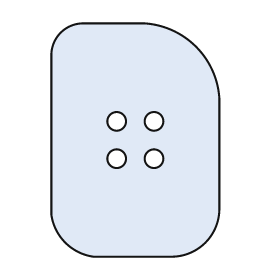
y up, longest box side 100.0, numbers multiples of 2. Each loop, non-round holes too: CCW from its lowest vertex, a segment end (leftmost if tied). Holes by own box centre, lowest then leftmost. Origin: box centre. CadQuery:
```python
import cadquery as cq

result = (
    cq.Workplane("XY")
    .moveTo(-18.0, -50.0)
    .lineTo(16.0, -50.0)
    .threePointArc((30.0, -44.0), (36.0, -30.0))
    .lineTo(36.0, 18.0)
    .threePointArc((26.0, 40.0), (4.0, 50.0))
    .lineTo(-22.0, 50.0)
    .threePointArc((-32.0, 46.0), (-36.0, 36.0))
    .lineTo(-36.0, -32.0)
    .threePointArc((-30.0, -44.0), (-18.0, -50.0))
    .close()
    .moveTo(-8.0, -8.0)
    .circle(4.0)
    .moveTo(8.0, -8.0)
    .circle(4.0)
    .moveTo(-8.0, 8.0)
    .circle(4.0)
    .moveTo(8.0, 8.0)
    .circle(4.0)
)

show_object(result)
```